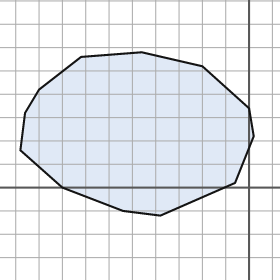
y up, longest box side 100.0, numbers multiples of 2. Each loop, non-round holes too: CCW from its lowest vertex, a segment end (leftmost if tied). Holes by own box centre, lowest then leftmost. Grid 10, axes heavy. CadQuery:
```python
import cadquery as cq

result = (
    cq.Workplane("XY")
    .moveTo(-38.0, -12.0)
    .lineTo(-6.0, 2.0)
    .lineTo(2.0, 22.0)
    .lineTo(0.0, 34.0)
    .lineTo(-20.0, 52.0)
    .lineTo(-46.0, 58.0)
    .lineTo(-72.0, 56.0)
    .lineTo(-90.0, 42.0)
    .lineTo(-96.0, 32.0)
    .lineTo(-98.0, 16.0)
    .lineTo(-80.0, 0.0)
    .lineTo(-54.0, -10.0)
    .close()
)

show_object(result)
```